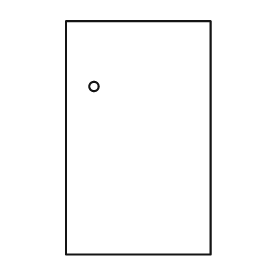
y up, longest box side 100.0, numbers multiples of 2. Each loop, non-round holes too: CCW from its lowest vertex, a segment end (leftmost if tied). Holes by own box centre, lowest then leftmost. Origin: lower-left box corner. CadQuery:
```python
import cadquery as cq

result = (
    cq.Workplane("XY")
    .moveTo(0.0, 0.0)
    .lineTo(62.0, 0.0)
    .lineTo(62.0, 100.0)
    .lineTo(0.0, 100.0)
    .close()
    .moveTo(12.0, 72.0)
    .circle(2.0)
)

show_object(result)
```